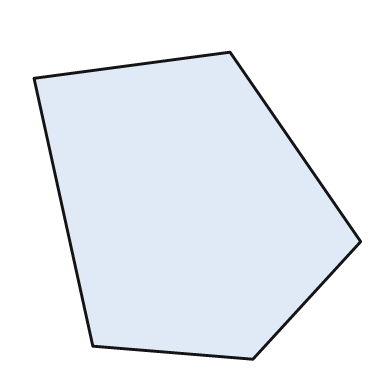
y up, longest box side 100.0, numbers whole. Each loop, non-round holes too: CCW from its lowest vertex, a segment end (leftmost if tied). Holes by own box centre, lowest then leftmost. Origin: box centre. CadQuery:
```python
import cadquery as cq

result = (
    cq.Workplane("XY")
    .moveTo(17.0, -47.0)
    .lineTo(50.0, -11.0)
    .lineTo(10.0, 47.0)
    .lineTo(-50.0, 39.0)
    .lineTo(-32.0, -43.0)
    .close()
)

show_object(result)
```